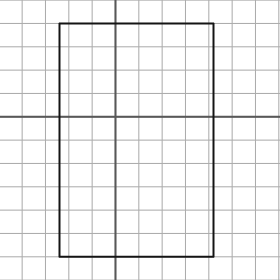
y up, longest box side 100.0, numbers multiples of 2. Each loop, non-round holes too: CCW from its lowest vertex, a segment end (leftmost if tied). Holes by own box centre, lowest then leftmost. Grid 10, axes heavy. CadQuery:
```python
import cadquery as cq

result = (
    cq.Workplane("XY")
    .moveTo(-24.0, -60.0)
    .lineTo(42.0, -60.0)
    .lineTo(42.0, 40.0)
    .lineTo(-24.0, 40.0)
    .close()
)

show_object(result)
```